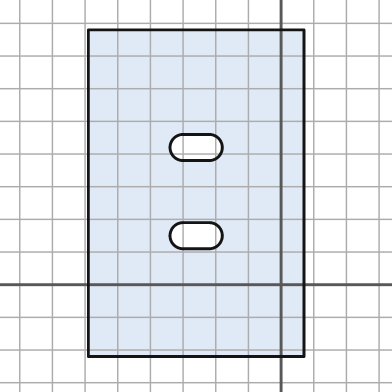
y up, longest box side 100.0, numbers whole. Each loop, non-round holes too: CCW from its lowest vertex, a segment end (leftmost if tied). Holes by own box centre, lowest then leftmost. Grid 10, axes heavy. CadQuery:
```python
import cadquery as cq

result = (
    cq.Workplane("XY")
    .moveTo(-59.0, -22.0)
    .lineTo(7.0, -22.0)
    .lineTo(7.0, 78.0)
    .lineTo(-59.0, 78.0)
    .close()
    .moveTo(-30.0, 11.0)
    .lineTo(-22.0, 11.0)
    .threePointArc((-18.0, 15.0), (-22.0, 19.0))
    .lineTo(-30.0, 19.0)
    .threePointArc((-34.0, 15.0), (-30.0, 11.0))
    .close()
    .moveTo(-30.0, 38.0)
    .lineTo(-22.0, 38.0)
    .threePointArc((-18.0, 42.0), (-22.0, 46.0))
    .lineTo(-30.0, 46.0)
    .threePointArc((-34.0, 42.0), (-30.0, 38.0))
    .close()
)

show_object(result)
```